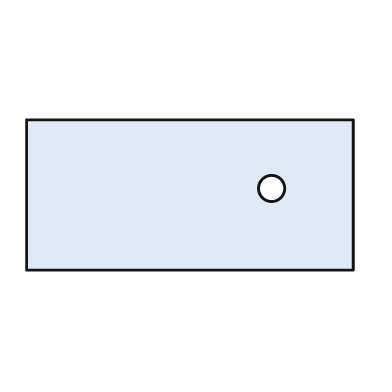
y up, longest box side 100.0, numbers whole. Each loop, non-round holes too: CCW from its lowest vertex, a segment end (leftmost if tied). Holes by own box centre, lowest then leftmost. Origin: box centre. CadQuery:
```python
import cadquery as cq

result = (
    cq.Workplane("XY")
    .moveTo(-50.0, -23.0)
    .lineTo(50.0, -23.0)
    .lineTo(50.0, 23.0)
    .lineTo(-50.0, 23.0)
    .close()
    .moveTo(25.0, 2.0)
    .circle(4.0)
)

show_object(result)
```